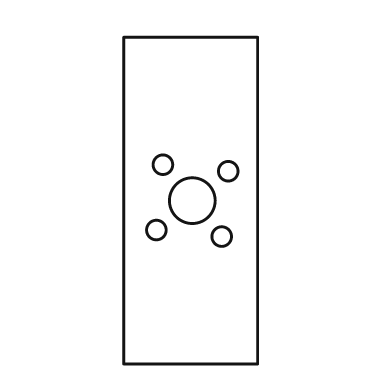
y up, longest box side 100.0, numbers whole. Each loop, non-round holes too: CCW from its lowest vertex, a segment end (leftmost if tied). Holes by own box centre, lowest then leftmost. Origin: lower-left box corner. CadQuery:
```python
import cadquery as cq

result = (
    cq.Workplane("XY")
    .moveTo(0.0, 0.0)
    .lineTo(41.0, 0.0)
    .lineTo(41.0, 100.0)
    .lineTo(0.0, 100.0)
    .close()
    .moveTo(30.0, 39.0)
    .circle(3.0)
    .moveTo(10.0, 41.0)
    .circle(3.0)
    .moveTo(21.0, 50.0)
    .circle(7.0)
    .moveTo(32.0, 59.0)
    .circle(3.0)
    .moveTo(12.0, 61.0)
    .circle(3.0)
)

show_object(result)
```